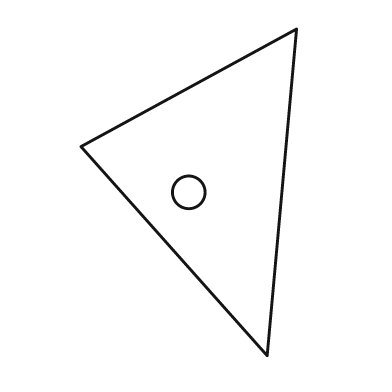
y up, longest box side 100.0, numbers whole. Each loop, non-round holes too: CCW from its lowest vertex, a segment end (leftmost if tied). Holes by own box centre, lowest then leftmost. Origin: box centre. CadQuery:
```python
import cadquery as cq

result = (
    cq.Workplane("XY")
    .moveTo(24.0, -50.0)
    .lineTo(33.0, 50.0)
    .lineTo(-33.0, 14.0)
    .close()
    .moveTo(0.0, 0.0)
    .circle(5.0)
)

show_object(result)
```